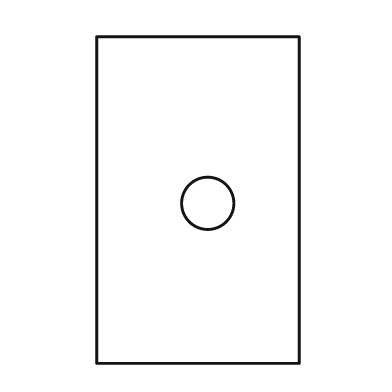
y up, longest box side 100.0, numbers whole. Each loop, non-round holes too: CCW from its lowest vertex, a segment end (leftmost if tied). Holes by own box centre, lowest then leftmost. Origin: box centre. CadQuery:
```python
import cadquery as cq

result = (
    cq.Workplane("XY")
    .moveTo(-31.0, -50.0)
    .lineTo(31.0, -50.0)
    .lineTo(31.0, 50.0)
    .lineTo(-31.0, 50.0)
    .close()
    .moveTo(3.0, -1.0)
    .circle(8.0)
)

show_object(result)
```